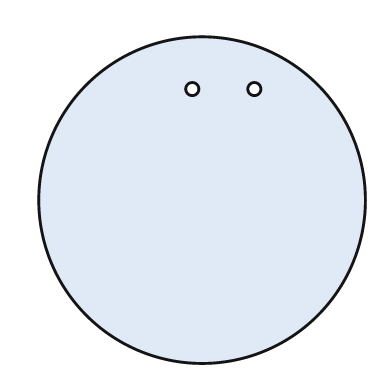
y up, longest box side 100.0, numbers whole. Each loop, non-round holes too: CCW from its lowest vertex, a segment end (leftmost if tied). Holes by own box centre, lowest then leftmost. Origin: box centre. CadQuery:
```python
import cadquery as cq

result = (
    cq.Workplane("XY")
    .moveTo(0.0, 0.0)
    .circle(50.0)
    .moveTo(-3.0, 34.0)
    .circle(2.0)
    .moveTo(16.0, 34.0)
    .circle(2.0)
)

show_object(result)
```